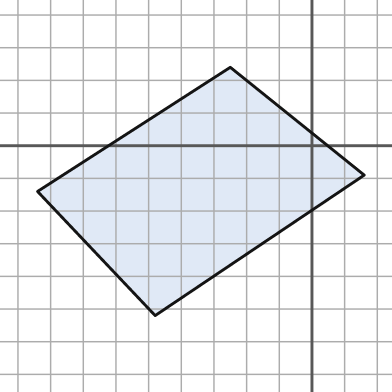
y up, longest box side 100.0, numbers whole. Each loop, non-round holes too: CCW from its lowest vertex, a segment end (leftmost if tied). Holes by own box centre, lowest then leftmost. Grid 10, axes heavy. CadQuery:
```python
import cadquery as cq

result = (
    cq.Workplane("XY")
    .moveTo(-48.0, -52.0)
    .lineTo(16.0, -9.0)
    .lineTo(-25.0, 24.0)
    .lineTo(-84.0, -14.0)
    .close()
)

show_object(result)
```